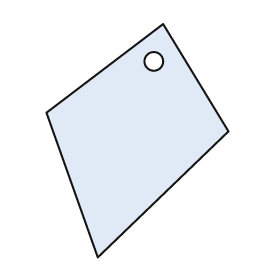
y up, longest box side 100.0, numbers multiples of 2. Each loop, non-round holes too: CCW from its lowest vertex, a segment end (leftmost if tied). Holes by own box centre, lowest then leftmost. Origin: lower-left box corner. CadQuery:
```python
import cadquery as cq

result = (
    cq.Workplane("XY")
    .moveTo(22.0, 0.0)
    .lineTo(78.0, 54.0)
    .lineTo(50.0, 100.0)
    .lineTo(0.0, 62.0)
    .close()
    .moveTo(46.0, 84.0)
    .circle(4.0)
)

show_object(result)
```